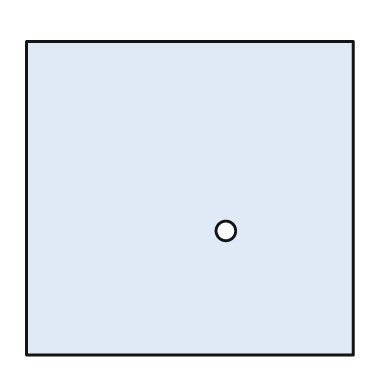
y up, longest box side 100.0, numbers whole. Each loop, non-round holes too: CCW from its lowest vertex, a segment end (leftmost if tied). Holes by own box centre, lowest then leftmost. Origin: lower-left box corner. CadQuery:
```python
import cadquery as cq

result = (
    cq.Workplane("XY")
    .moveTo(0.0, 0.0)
    .lineTo(100.0, 0.0)
    .lineTo(100.0, 96.0)
    .lineTo(0.0, 96.0)
    .close()
    .moveTo(61.0, 38.0)
    .circle(3.0)
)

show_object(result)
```